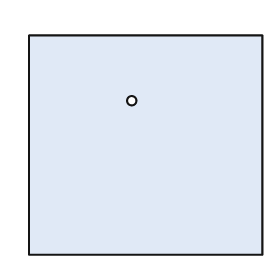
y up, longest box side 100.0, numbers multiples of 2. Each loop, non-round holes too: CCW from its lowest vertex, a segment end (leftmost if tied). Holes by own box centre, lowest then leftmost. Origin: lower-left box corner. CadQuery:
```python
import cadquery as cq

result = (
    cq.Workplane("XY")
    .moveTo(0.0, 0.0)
    .lineTo(100.0, 0.0)
    .lineTo(100.0, 94.0)
    .lineTo(0.0, 94.0)
    .close()
    .moveTo(44.0, 66.0)
    .circle(2.0)
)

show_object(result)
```